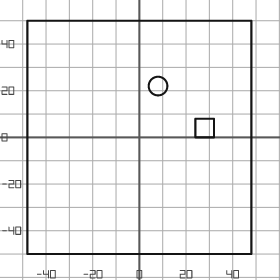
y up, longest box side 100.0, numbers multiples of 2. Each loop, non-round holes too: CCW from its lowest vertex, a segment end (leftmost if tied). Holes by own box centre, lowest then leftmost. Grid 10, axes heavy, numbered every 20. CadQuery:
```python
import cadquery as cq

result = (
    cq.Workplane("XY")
    .moveTo(-48.0, -50.0)
    .lineTo(48.0, -50.0)
    .lineTo(48.0, 50.0)
    .lineTo(-48.0, 50.0)
    .close()
    .moveTo(24.0, 0.0)
    .lineTo(32.0, 0.0)
    .lineTo(32.0, 8.0)
    .lineTo(24.0, 8.0)
    .close()
    .moveTo(8.0, 22.0)
    .circle(4.0)
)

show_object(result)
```